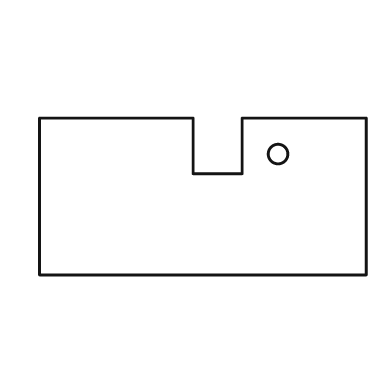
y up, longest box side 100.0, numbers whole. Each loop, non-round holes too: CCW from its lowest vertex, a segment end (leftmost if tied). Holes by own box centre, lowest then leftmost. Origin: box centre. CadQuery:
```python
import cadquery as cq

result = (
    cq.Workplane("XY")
    .moveTo(-50.0, -24.0)
    .lineTo(50.0, -24.0)
    .lineTo(50.0, 24.0)
    .lineTo(12.0, 24.0)
    .lineTo(12.0, 7.0)
    .lineTo(-3.0, 7.0)
    .lineTo(-3.0, 24.0)
    .lineTo(-50.0, 24.0)
    .close()
    .moveTo(23.0, 13.0)
    .circle(3.0)
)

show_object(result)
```